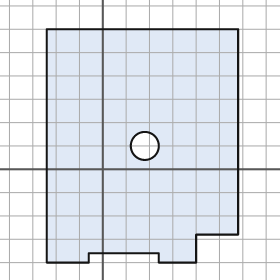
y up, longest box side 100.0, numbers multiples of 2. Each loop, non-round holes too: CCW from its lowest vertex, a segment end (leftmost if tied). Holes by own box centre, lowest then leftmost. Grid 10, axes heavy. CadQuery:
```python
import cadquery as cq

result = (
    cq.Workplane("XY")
    .moveTo(-24.0, -40.0)
    .lineTo(-6.0, -40.0)
    .lineTo(-6.0, -36.0)
    .lineTo(24.0, -36.0)
    .lineTo(24.0, -40.0)
    .lineTo(40.0, -40.0)
    .lineTo(40.0, -28.0)
    .lineTo(58.0, -28.0)
    .lineTo(58.0, 60.0)
    .lineTo(-24.0, 60.0)
    .close()
    .moveTo(18.0, 10.0)
    .circle(6.0)
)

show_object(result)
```